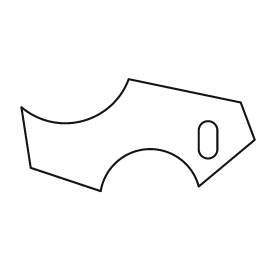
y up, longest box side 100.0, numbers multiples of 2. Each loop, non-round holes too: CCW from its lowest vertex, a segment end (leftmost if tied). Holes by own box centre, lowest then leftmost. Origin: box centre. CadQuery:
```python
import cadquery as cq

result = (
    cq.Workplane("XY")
    .moveTo(-16.0, -24.0)
    .threePointArc((4.0, -6.0), (26.0, -22.0))
    .lineTo(50.0, -2.0)
    .lineTo(44.0, 14.0)
    .lineTo(-4.0, 24.0)
    .threePointArc((-24.0, 6.0), (-50.0, 12.0))
    .lineTo(-46.0, -14.0)
    .close()
    .moveTo(26.0, -6.0)
    .threePointArc((30.0, -10.0), (34.0, -6.0))
    .lineTo(34.0, 2.0)
    .threePointArc((30.0, 6.0), (26.0, 2.0))
    .close()
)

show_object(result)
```